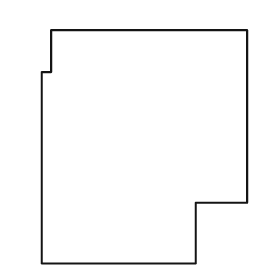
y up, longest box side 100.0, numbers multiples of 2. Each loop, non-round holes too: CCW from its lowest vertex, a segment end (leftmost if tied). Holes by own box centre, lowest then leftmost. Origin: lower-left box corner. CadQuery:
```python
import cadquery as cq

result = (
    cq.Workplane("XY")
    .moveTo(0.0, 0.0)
    .lineTo(66.0, 0.0)
    .lineTo(66.0, 26.0)
    .lineTo(88.0, 26.0)
    .lineTo(88.0, 100.0)
    .lineTo(4.0, 100.0)
    .lineTo(4.0, 82.0)
    .lineTo(0.0, 82.0)
    .close()
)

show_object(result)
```